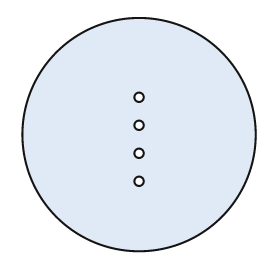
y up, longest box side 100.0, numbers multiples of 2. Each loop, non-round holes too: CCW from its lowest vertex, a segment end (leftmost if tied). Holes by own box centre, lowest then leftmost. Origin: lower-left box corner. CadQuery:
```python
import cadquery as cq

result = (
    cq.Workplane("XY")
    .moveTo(50.0, 50.0)
    .circle(50.0)
    .moveTo(50.0, 30.0)
    .circle(2.0)
    .moveTo(50.0, 42.0)
    .circle(2.0)
    .moveTo(50.0, 54.0)
    .circle(2.0)
    .moveTo(50.0, 66.0)
    .circle(2.0)
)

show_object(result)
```